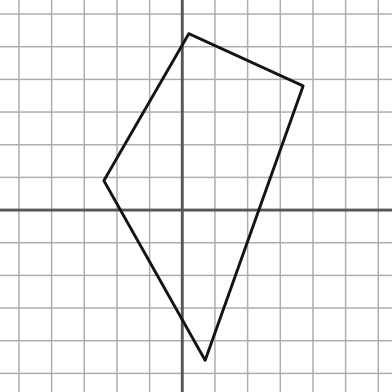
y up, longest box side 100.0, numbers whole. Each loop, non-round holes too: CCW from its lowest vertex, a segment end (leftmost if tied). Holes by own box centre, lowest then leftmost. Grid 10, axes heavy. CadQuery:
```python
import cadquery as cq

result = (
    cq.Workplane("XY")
    .moveTo(7.0, -46.0)
    .lineTo(37.0, 38.0)
    .lineTo(2.0, 54.0)
    .lineTo(-24.0, 9.0)
    .close()
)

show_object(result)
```